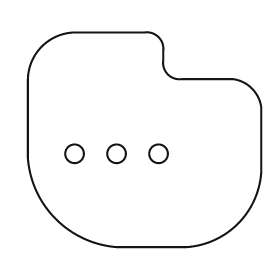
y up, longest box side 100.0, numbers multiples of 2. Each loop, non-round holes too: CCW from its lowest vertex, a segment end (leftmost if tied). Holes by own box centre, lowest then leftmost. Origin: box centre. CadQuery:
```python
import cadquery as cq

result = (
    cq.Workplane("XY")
    .moveTo(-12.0, -46.0)
    .lineTo(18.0, -46.0)
    .threePointArc((40.0, -36.0), (50.0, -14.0))
    .lineTo(50.0, 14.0)
    .threePointArc((46.0, 22.0), (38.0, 26.0))
    .lineTo(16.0, 26.0)
    .threePointArc((10.0, 28.0), (8.0, 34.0))
    .lineTo(8.0, 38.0)
    .threePointArc((6.0, 44.0), (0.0, 46.0))
    .lineTo(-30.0, 46.0)
    .threePointArc((-44.0, 40.0), (-50.0, 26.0))
    .lineTo(-50.0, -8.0)
    .threePointArc((-38.0, -34.0), (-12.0, -46.0))
    .close()
    .moveTo(-30.0, -6.0)
    .circle(4.0)
    .moveTo(-12.0, -6.0)
    .circle(4.0)
    .moveTo(6.0, -6.0)
    .circle(4.0)
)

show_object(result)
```